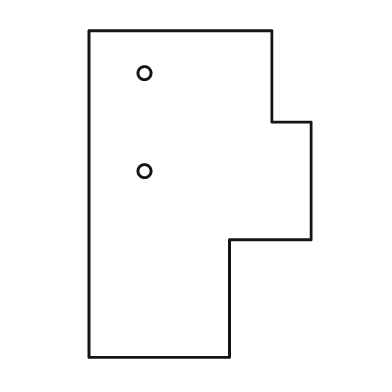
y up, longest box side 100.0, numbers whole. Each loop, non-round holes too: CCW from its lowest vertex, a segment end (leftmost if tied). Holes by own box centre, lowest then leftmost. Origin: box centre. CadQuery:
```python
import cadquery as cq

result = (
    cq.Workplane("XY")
    .moveTo(-34.0, -50.0)
    .lineTo(9.0, -50.0)
    .lineTo(9.0, -14.0)
    .lineTo(34.0, -14.0)
    .lineTo(34.0, 22.0)
    .lineTo(22.0, 22.0)
    .lineTo(22.0, 50.0)
    .lineTo(-34.0, 50.0)
    .close()
    .moveTo(-17.0, 7.0)
    .circle(2.0)
    .moveTo(-17.0, 37.0)
    .circle(2.0)
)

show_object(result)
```